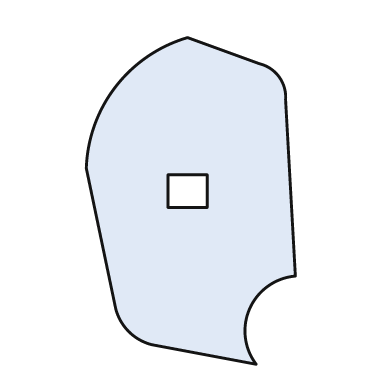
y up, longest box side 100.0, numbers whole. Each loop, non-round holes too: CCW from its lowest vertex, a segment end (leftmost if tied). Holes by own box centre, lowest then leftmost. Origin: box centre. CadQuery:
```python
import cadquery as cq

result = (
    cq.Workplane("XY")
    .moveTo(20.0, -50.0)
    .threePointArc((18.0, -33.0), (32.0, -23.0))
    .lineTo(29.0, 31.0)
    .threePointArc((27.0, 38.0), (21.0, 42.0))
    .lineTo(-1.0, 50.0)
    .threePointArc((-23.0, 35.0), (-32.0, 10.0))
    .lineTo(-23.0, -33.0)
    .threePointArc((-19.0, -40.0), (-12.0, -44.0))
    .close()
    .moveTo(-7.0, -2.0)
    .lineTo(5.0, -2.0)
    .lineTo(5.0, 8.0)
    .lineTo(-7.0, 8.0)
    .close()
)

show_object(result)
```